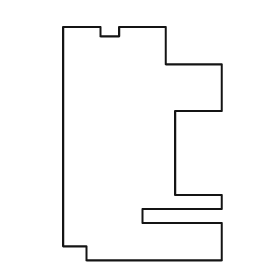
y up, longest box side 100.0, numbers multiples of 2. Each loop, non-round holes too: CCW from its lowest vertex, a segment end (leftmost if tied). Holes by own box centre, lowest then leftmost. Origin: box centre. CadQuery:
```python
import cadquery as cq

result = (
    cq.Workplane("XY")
    .moveTo(-24.0, -50.0)
    .lineTo(34.0, -50.0)
    .lineTo(34.0, -34.0)
    .lineTo(0.0, -34.0)
    .lineTo(0.0, -28.0)
    .lineTo(34.0, -28.0)
    .lineTo(34.0, -22.0)
    .lineTo(14.0, -22.0)
    .lineTo(14.0, 14.0)
    .lineTo(34.0, 14.0)
    .lineTo(34.0, 34.0)
    .lineTo(10.0, 34.0)
    .lineTo(10.0, 50.0)
    .lineTo(-10.0, 50.0)
    .lineTo(-10.0, 46.0)
    .lineTo(-18.0, 46.0)
    .lineTo(-18.0, 50.0)
    .lineTo(-34.0, 50.0)
    .lineTo(-34.0, -44.0)
    .lineTo(-24.0, -44.0)
    .close()
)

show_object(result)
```